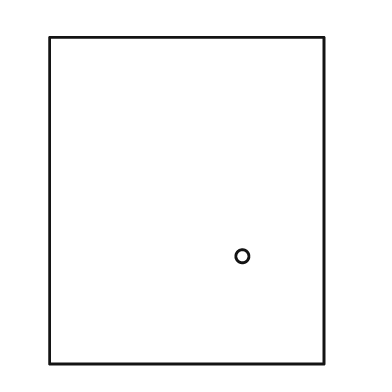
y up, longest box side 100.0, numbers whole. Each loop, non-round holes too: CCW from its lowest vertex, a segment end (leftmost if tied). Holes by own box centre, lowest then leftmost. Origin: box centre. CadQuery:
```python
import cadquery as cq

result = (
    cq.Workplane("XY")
    .moveTo(-42.0, -50.0)
    .lineTo(42.0, -50.0)
    .lineTo(42.0, 50.0)
    .lineTo(-42.0, 50.0)
    .close()
    .moveTo(17.0, -17.0)
    .circle(2.0)
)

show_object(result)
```